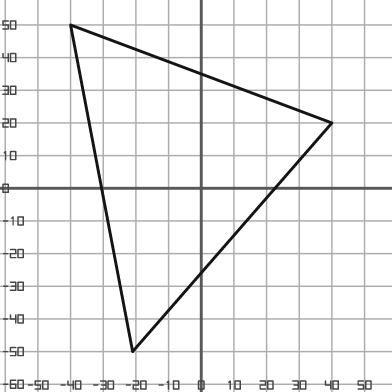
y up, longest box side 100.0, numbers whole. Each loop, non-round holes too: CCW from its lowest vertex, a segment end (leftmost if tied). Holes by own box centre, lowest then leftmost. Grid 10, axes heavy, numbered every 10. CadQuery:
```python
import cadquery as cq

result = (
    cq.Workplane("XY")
    .moveTo(-21.0, -50.0)
    .lineTo(40.0, 20.0)
    .lineTo(-40.0, 50.0)
    .close()
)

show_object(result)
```